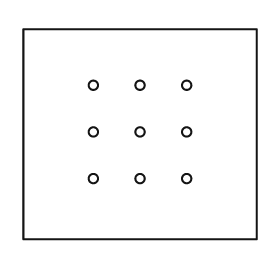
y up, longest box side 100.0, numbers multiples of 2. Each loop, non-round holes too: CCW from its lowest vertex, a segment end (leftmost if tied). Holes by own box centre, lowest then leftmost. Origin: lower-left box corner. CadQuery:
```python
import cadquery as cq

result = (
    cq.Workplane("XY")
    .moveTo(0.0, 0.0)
    .lineTo(100.0, 0.0)
    .lineTo(100.0, 90.0)
    .lineTo(0.0, 90.0)
    .close()
    .moveTo(30.0, 26.0)
    .circle(2.0)
    .moveTo(50.0, 26.0)
    .circle(2.0)
    .moveTo(70.0, 26.0)
    .circle(2.0)
    .moveTo(30.0, 46.0)
    .circle(2.0)
    .moveTo(50.0, 46.0)
    .circle(2.0)
    .moveTo(70.0, 46.0)
    .circle(2.0)
    .moveTo(30.0, 66.0)
    .circle(2.0)
    .moveTo(50.0, 66.0)
    .circle(2.0)
    .moveTo(70.0, 66.0)
    .circle(2.0)
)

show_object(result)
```